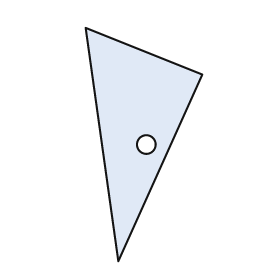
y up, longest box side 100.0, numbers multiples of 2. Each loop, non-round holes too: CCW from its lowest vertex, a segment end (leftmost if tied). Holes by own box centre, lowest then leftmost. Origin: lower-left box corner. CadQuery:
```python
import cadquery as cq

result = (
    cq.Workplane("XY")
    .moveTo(14.0, 0.0)
    .lineTo(50.0, 80.0)
    .lineTo(0.0, 100.0)
    .close()
    .moveTo(26.0, 50.0)
    .circle(4.0)
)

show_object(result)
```